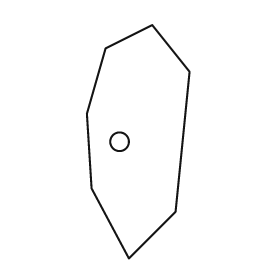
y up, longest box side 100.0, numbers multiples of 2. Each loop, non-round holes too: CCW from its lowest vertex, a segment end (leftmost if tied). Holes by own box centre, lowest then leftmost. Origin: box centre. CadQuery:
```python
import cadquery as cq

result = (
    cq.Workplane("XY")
    .moveTo(-4.0, -50.0)
    .lineTo(16.0, -30.0)
    .lineTo(22.0, 30.0)
    .lineTo(6.0, 50.0)
    .lineTo(-14.0, 40.0)
    .lineTo(-22.0, 12.0)
    .lineTo(-20.0, -20.0)
    .close()
    .moveTo(-8.0, 0.0)
    .circle(4.0)
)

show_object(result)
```